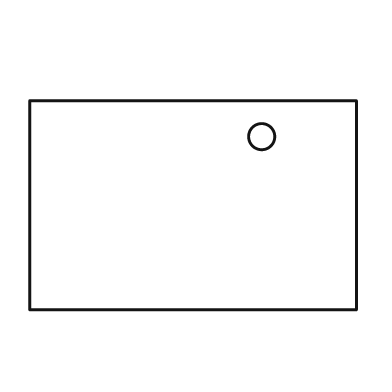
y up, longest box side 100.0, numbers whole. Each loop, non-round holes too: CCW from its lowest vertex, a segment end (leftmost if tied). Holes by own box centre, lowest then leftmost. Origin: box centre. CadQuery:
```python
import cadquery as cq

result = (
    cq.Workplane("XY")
    .moveTo(-50.0, -32.0)
    .lineTo(50.0, -32.0)
    .lineTo(50.0, 32.0)
    .lineTo(-50.0, 32.0)
    .close()
    .moveTo(21.0, 21.0)
    .circle(4.0)
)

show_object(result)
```